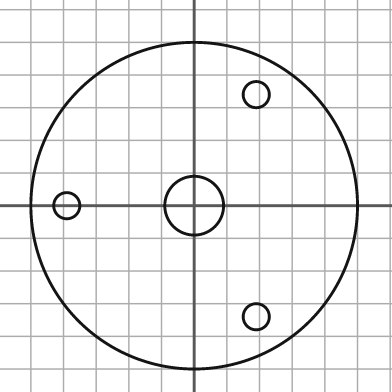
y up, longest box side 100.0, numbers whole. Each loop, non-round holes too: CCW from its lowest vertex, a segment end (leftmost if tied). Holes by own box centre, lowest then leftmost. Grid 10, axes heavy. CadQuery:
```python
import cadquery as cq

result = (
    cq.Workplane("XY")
    .moveTo(0.0, 0.0)
    .circle(50.0)
    .moveTo(19.0, -34.0)
    .circle(4.0)
    .moveTo(-39.0, 0.0)
    .circle(4.0)
    .moveTo(0.0, 0.0)
    .circle(9.0)
    .moveTo(19.0, 34.0)
    .circle(4.0)
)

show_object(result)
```